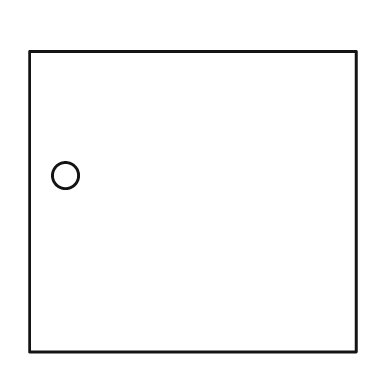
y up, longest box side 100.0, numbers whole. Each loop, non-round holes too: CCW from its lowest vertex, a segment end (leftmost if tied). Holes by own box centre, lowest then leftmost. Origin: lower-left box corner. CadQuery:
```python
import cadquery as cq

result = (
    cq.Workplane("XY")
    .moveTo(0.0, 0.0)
    .lineTo(100.0, 0.0)
    .lineTo(100.0, 92.0)
    .lineTo(0.0, 92.0)
    .close()
    .moveTo(11.0, 54.0)
    .circle(4.0)
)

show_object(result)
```